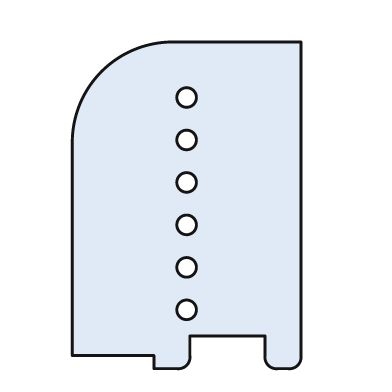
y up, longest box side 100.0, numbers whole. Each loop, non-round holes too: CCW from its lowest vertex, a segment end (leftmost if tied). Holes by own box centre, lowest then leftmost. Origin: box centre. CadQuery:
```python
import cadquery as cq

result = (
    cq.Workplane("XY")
    .moveTo(-10.0, -50.0)
    .lineTo(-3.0, -50.0)
    .threePointArc((0.0, -49.0), (1.0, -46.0))
    .lineTo(1.0, -40.0)
    .lineTo(24.0, -40.0)
    .lineTo(24.0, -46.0)
    .threePointArc((25.0, -49.0), (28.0, -50.0))
    .lineTo(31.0, -50.0)
    .threePointArc((34.0, -49.0), (35.0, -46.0))
    .lineTo(35.0, 50.0)
    .lineTo(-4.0, 50.0)
    .threePointArc((-26.0, 41.0), (-35.0, 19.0))
    .lineTo(-35.0, -46.0)
    .lineTo(-10.0, -46.0)
    .close()
    .moveTo(0.0, -32.0)
    .circle(3.0)
    .moveTo(0.0, -19.0)
    .circle(3.0)
    .moveTo(0.0, -6.0)
    .circle(3.0)
    .moveTo(0.0, 7.0)
    .circle(3.0)
    .moveTo(0.0, 20.0)
    .circle(3.0)
    .moveTo(0.0, 33.0)
    .circle(3.0)
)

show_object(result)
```